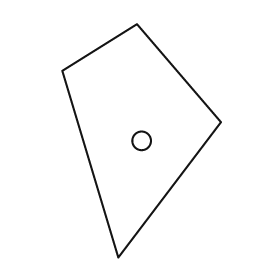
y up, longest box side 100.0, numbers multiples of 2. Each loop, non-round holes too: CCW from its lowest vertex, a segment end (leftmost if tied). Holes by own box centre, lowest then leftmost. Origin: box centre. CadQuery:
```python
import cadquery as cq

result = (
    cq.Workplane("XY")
    .moveTo(-10.0, -50.0)
    .lineTo(34.0, 8.0)
    .lineTo(-2.0, 50.0)
    .lineTo(-34.0, 30.0)
    .close()
    .moveTo(0.0, 0.0)
    .circle(4.0)
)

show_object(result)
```